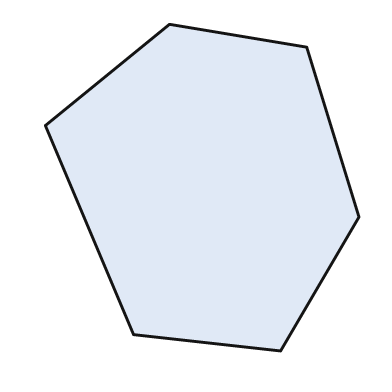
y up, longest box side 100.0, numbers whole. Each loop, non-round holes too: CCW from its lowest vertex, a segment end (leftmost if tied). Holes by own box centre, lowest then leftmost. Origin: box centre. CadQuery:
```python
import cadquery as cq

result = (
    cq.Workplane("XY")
    .moveTo(24.0, -50.0)
    .lineTo(48.0, -9.0)
    .lineTo(32.0, 43.0)
    .lineTo(-10.0, 50.0)
    .lineTo(-48.0, 19.0)
    .lineTo(-21.0, -45.0)
    .close()
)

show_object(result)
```